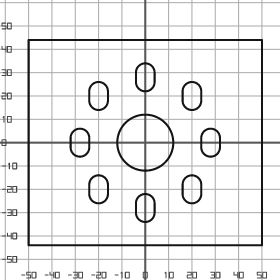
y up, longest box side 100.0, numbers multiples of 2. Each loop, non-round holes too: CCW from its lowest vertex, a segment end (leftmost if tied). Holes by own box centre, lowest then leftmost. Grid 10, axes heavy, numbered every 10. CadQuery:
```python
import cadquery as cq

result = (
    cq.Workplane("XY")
    .moveTo(-50.0, -44.0)
    .lineTo(50.0, -44.0)
    .lineTo(50.0, 44.0)
    .lineTo(-50.0, 44.0)
    .close()
    .moveTo(-4.0, -30.0)
    .threePointArc((0.0, -34.0), (4.0, -30.0))
    .lineTo(4.0, -26.0)
    .threePointArc((0.0, -22.0), (-4.0, -26.0))
    .close()
    .moveTo(-24.0, -22.0)
    .threePointArc((-20.0, -26.0), (-16.0, -22.0))
    .lineTo(-16.0, -18.0)
    .threePointArc((-20.0, -14.0), (-24.0, -18.0))
    .close()
    .moveTo(16.0, -22.0)
    .threePointArc((20.0, -26.0), (24.0, -22.0))
    .lineTo(24.0, -18.0)
    .threePointArc((20.0, -14.0), (16.0, -18.0))
    .close()
    .moveTo(-32.0, -2.0)
    .threePointArc((-28.0, -6.0), (-24.0, -2.0))
    .lineTo(-24.0, 2.0)
    .threePointArc((-28.0, 6.0), (-32.0, 2.0))
    .close()
    .moveTo(0.0, 0.0)
    .circle(12.0)
    .moveTo(24.0, -2.0)
    .threePointArc((28.0, -6.0), (32.0, -2.0))
    .lineTo(32.0, 2.0)
    .threePointArc((28.0, 6.0), (24.0, 2.0))
    .close()
    .moveTo(-24.0, 18.0)
    .threePointArc((-20.0, 14.0), (-16.0, 18.0))
    .lineTo(-16.0, 22.0)
    .threePointArc((-20.0, 26.0), (-24.0, 22.0))
    .close()
    .moveTo(16.0, 18.0)
    .threePointArc((20.0, 14.0), (24.0, 18.0))
    .lineTo(24.0, 22.0)
    .threePointArc((20.0, 26.0), (16.0, 22.0))
    .close()
    .moveTo(-4.0, 26.0)
    .threePointArc((0.0, 22.0), (4.0, 26.0))
    .lineTo(4.0, 30.0)
    .threePointArc((0.0, 34.0), (-4.0, 30.0))
    .close()
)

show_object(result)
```